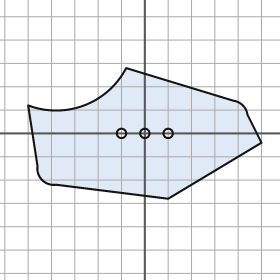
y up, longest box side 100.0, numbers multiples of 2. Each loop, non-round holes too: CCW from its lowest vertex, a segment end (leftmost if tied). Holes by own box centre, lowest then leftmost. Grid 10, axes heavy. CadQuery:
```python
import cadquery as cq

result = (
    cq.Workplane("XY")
    .moveTo(10.0, -28.0)
    .lineTo(50.0, -4.0)
    .lineTo(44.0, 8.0)
    .threePointArc((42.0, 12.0), (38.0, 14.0))
    .lineTo(-8.0, 28.0)
    .threePointArc((-26.0, 12.0), (-50.0, 12.0))
    .lineTo(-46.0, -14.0)
    .threePointArc((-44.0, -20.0), (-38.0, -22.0))
    .close()
    .moveTo(-10.0, 0.0)
    .circle(2.0)
    .moveTo(0.0, 0.0)
    .circle(2.0)
    .moveTo(10.0, 0.0)
    .circle(2.0)
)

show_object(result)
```